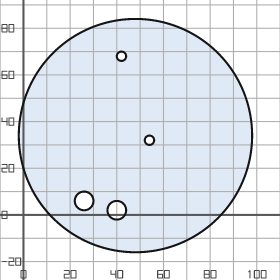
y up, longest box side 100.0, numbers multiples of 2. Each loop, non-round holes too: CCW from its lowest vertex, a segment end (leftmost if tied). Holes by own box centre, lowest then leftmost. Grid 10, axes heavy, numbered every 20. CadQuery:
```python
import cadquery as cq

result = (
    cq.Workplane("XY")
    .moveTo(48.0, 34.0)
    .circle(50.0)
    .moveTo(40.0, 2.0)
    .circle(4.0)
    .moveTo(26.0, 6.0)
    .circle(4.0)
    .moveTo(54.0, 32.0)
    .circle(2.0)
    .moveTo(42.0, 68.0)
    .circle(2.0)
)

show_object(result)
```